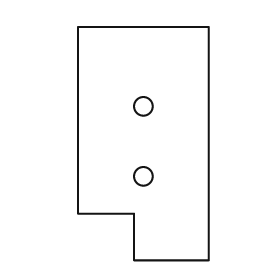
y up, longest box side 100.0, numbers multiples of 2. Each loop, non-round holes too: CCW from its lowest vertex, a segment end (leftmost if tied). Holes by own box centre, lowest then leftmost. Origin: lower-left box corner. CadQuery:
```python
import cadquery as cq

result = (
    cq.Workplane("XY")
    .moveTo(24.0, 0.0)
    .lineTo(56.0, 0.0)
    .lineTo(56.0, 100.0)
    .lineTo(0.0, 100.0)
    .lineTo(0.0, 20.0)
    .lineTo(24.0, 20.0)
    .close()
    .moveTo(28.0, 36.0)
    .circle(4.0)
    .moveTo(28.0, 66.0)
    .circle(4.0)
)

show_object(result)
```